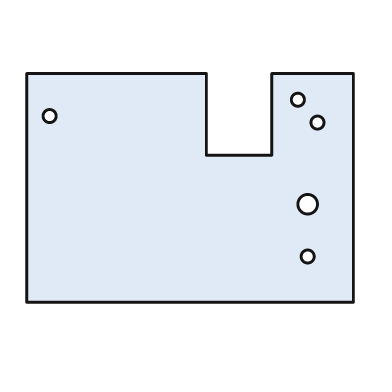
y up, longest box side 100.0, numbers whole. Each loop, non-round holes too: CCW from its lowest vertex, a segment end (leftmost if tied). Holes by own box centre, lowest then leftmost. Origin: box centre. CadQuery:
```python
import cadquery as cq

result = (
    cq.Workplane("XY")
    .moveTo(-50.0, -35.0)
    .lineTo(50.0, -35.0)
    .lineTo(50.0, 35.0)
    .lineTo(25.0, 35.0)
    .lineTo(25.0, 10.0)
    .lineTo(5.0, 10.0)
    .lineTo(5.0, 35.0)
    .lineTo(-50.0, 35.0)
    .close()
    .moveTo(36.0, -21.0)
    .circle(2.0)
    .moveTo(36.0, -5.0)
    .circle(3.0)
    .moveTo(39.0, 20.0)
    .circle(2.0)
    .moveTo(-43.0, 22.0)
    .circle(2.0)
    .moveTo(33.0, 27.0)
    .circle(2.0)
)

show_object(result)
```